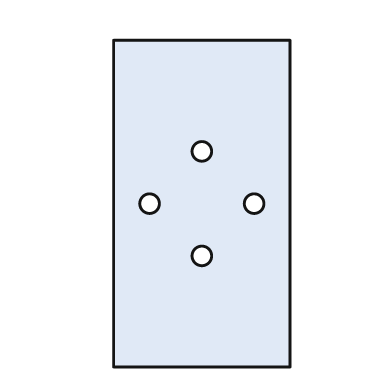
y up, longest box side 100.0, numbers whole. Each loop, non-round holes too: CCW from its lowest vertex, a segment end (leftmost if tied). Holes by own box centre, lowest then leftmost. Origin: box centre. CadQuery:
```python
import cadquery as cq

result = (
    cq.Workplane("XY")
    .moveTo(-27.0, -50.0)
    .lineTo(27.0, -50.0)
    .lineTo(27.0, 50.0)
    .lineTo(-27.0, 50.0)
    .close()
    .moveTo(0.0, -16.0)
    .circle(3.0)
    .moveTo(-16.0, 0.0)
    .circle(3.0)
    .moveTo(16.0, 0.0)
    .circle(3.0)
    .moveTo(0.0, 16.0)
    .circle(3.0)
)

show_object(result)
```